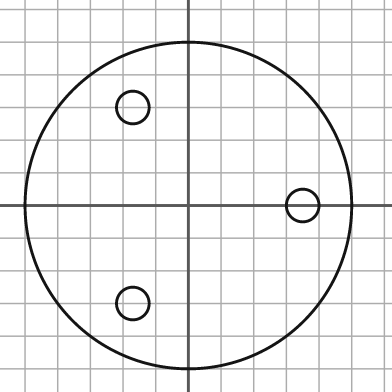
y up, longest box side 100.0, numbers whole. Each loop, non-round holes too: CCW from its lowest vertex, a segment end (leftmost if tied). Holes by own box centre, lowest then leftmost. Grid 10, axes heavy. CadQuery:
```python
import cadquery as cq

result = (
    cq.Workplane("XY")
    .moveTo(0.0, 0.0)
    .circle(50.0)
    .moveTo(-17.0, -30.0)
    .circle(5.0)
    .moveTo(35.0, 0.0)
    .circle(5.0)
    .moveTo(-17.0, 30.0)
    .circle(5.0)
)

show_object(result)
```